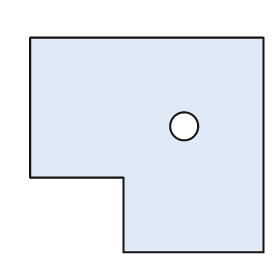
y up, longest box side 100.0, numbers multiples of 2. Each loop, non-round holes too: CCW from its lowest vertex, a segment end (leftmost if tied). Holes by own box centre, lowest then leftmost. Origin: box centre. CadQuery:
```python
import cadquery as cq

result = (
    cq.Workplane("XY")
    .moveTo(-10.0, -46.0)
    .lineTo(50.0, -46.0)
    .lineTo(50.0, 46.0)
    .lineTo(-50.0, 46.0)
    .lineTo(-50.0, -14.0)
    .lineTo(-10.0, -14.0)
    .close()
    .moveTo(16.0, 8.0)
    .circle(6.0)
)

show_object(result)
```